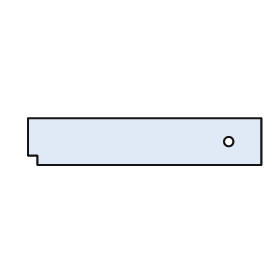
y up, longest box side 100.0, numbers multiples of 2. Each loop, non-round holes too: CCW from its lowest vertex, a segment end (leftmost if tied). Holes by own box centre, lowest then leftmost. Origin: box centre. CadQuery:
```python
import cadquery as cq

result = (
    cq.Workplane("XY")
    .moveTo(-46.0, -10.0)
    .lineTo(50.0, -10.0)
    .lineTo(50.0, 10.0)
    .lineTo(-50.0, 10.0)
    .lineTo(-50.0, -6.0)
    .lineTo(-46.0, -6.0)
    .close()
    .moveTo(36.0, 0.0)
    .circle(2.0)
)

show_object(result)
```